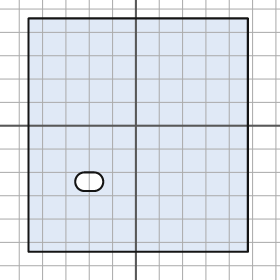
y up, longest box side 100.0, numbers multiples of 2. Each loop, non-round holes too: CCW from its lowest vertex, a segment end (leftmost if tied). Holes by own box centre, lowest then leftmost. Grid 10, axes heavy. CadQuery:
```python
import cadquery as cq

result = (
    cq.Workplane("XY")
    .moveTo(-46.0, -54.0)
    .lineTo(48.0, -54.0)
    .lineTo(48.0, 46.0)
    .lineTo(-46.0, 46.0)
    .close()
    .moveTo(-22.0, -28.0)
    .lineTo(-18.0, -28.0)
    .threePointArc((-14.0, -24.0), (-18.0, -20.0))
    .lineTo(-22.0, -20.0)
    .threePointArc((-26.0, -24.0), (-22.0, -28.0))
    .close()
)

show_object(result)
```